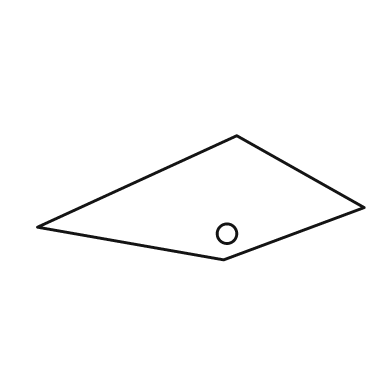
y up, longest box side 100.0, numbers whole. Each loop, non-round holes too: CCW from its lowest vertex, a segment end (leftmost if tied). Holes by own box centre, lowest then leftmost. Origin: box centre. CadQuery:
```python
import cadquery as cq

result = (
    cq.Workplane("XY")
    .moveTo(7.0, -19.0)
    .lineTo(50.0, -3.0)
    .lineTo(11.0, 19.0)
    .lineTo(-50.0, -9.0)
    .close()
    .moveTo(8.0, -11.0)
    .circle(3.0)
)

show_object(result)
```